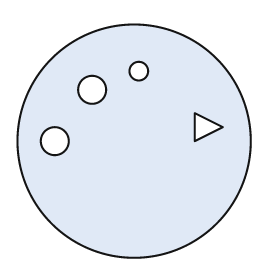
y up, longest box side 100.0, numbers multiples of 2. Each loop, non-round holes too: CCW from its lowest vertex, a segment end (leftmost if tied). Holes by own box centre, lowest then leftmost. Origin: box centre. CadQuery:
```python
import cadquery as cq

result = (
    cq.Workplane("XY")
    .moveTo(0.0, 0.0)
    .circle(50.0)
    .moveTo(-34.0, 0.0)
    .circle(6.0)
    .moveTo(26.0, 0.0)
    .lineTo(38.0, 6.0)
    .lineTo(26.0, 12.0)
    .close()
    .moveTo(-18.0, 22.0)
    .circle(6.0)
    .moveTo(2.0, 30.0)
    .circle(4.0)
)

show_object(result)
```